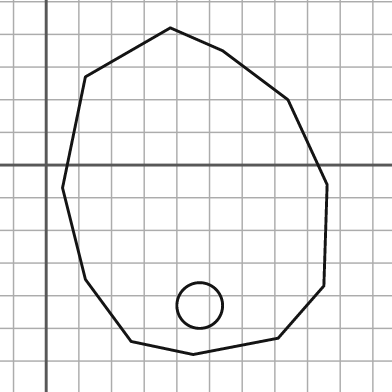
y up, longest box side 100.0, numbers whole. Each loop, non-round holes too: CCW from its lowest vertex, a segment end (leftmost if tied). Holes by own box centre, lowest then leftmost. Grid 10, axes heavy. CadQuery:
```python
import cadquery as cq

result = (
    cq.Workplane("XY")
    .moveTo(45.0, -58.0)
    .lineTo(71.0, -53.0)
    .lineTo(85.0, -37.0)
    .lineTo(86.0, -6.0)
    .lineTo(74.0, 20.0)
    .lineTo(54.0, 35.0)
    .lineTo(38.0, 42.0)
    .lineTo(12.0, 27.0)
    .lineTo(5.0, -7.0)
    .lineTo(12.0, -35.0)
    .lineTo(26.0, -54.0)
    .close()
    .moveTo(47.0, -43.0)
    .circle(7.0)
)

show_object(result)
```